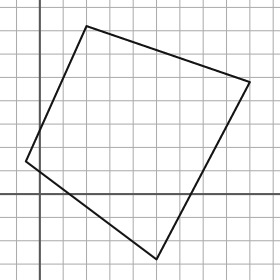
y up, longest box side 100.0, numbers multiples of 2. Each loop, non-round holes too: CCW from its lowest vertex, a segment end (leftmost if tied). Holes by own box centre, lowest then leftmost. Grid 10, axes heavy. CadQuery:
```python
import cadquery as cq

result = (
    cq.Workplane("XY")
    .moveTo(50.0, -28.0)
    .lineTo(90.0, 48.0)
    .lineTo(20.0, 72.0)
    .lineTo(-6.0, 14.0)
    .close()
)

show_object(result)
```